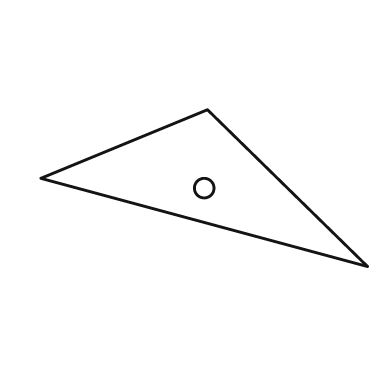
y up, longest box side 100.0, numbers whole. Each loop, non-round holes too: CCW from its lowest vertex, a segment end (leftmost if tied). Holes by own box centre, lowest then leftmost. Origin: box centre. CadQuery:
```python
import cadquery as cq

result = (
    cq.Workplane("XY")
    .moveTo(50.0, -24.0)
    .lineTo(1.0, 24.0)
    .lineTo(-50.0, 3.0)
    .close()
    .moveTo(0.0, 0.0)
    .circle(3.0)
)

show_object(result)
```